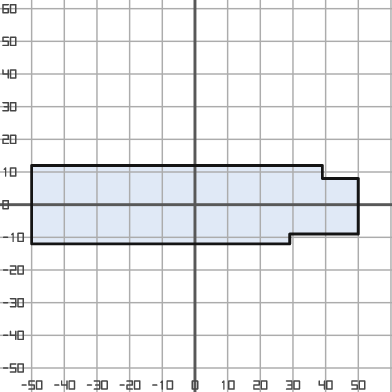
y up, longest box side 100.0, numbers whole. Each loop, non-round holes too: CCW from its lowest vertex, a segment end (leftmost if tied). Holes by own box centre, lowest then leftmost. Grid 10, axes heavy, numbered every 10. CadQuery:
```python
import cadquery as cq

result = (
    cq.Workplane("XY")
    .moveTo(-50.0, -12.0)
    .lineTo(29.0, -12.0)
    .lineTo(29.0, -9.0)
    .lineTo(50.0, -9.0)
    .lineTo(50.0, 8.0)
    .lineTo(39.0, 8.0)
    .lineTo(39.0, 12.0)
    .lineTo(-50.0, 12.0)
    .close()
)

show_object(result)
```